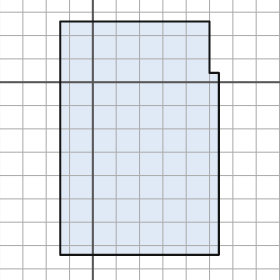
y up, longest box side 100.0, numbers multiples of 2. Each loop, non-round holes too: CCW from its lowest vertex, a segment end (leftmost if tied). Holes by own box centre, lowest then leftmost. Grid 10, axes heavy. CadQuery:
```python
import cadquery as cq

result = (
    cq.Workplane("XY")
    .moveTo(-14.0, -74.0)
    .lineTo(54.0, -74.0)
    .lineTo(54.0, 4.0)
    .lineTo(50.0, 4.0)
    .lineTo(50.0, 26.0)
    .lineTo(-14.0, 26.0)
    .close()
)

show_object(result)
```